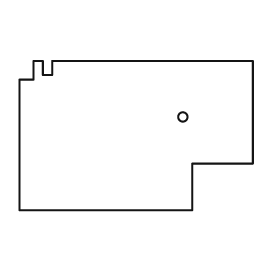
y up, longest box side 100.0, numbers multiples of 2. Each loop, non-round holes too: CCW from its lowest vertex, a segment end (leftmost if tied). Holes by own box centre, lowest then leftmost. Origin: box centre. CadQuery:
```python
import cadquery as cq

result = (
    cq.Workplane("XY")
    .moveTo(-50.0, -32.0)
    .lineTo(24.0, -32.0)
    .lineTo(24.0, -12.0)
    .lineTo(50.0, -12.0)
    .lineTo(50.0, 32.0)
    .lineTo(-36.0, 32.0)
    .lineTo(-36.0, 26.0)
    .lineTo(-40.0, 26.0)
    .lineTo(-40.0, 32.0)
    .lineTo(-44.0, 32.0)
    .lineTo(-44.0, 24.0)
    .lineTo(-50.0, 24.0)
    .close()
    .moveTo(20.0, 8.0)
    .circle(2.0)
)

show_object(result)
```